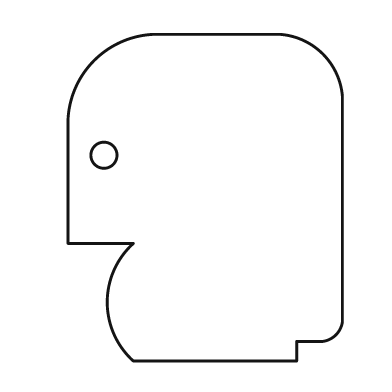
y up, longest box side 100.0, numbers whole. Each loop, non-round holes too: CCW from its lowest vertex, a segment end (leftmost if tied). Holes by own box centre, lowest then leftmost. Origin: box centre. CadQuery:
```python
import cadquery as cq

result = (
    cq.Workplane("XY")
    .moveTo(-22.0, -50.0)
    .lineTo(28.0, -50.0)
    .lineTo(28.0, -44.0)
    .lineTo(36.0, -44.0)
    .threePointArc((40.0, -42.0), (42.0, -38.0))
    .lineTo(42.0, 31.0)
    .threePointArc((36.0, 44.0), (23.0, 50.0))
    .lineTo(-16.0, 50.0)
    .threePointArc((-34.0, 42.0), (-42.0, 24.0))
    .lineTo(-42.0, -14.0)
    .lineTo(-22.0, -14.0)
    .threePointArc((-30.0, -32.0), (-22.0, -50.0))
    .close()
    .moveTo(-31.0, 13.0)
    .circle(4.0)
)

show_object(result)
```